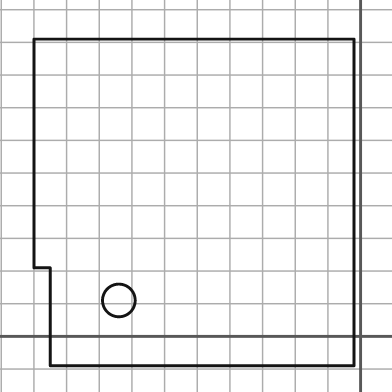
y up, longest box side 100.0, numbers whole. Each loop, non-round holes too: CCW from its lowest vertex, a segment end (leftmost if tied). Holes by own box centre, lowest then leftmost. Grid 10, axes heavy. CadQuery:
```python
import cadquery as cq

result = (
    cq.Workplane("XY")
    .moveTo(-95.0, -9.0)
    .lineTo(-2.0, -9.0)
    .lineTo(-2.0, 91.0)
    .lineTo(-100.0, 91.0)
    .lineTo(-100.0, 21.0)
    .lineTo(-95.0, 21.0)
    .close()
    .moveTo(-74.0, 11.0)
    .circle(5.0)
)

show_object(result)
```